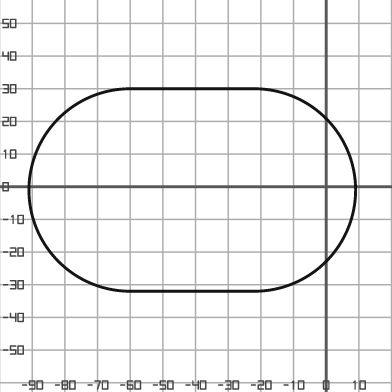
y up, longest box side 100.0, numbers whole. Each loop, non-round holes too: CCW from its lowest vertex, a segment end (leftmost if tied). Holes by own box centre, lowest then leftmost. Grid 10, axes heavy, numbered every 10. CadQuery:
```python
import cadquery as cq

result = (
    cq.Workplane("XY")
    .moveTo(-60.0, -32.0)
    .lineTo(-22.0, -32.0)
    .threePointArc((9.0, -1.0), (-22.0, 30.0))
    .lineTo(-60.0, 30.0)
    .threePointArc((-91.0, -1.0), (-60.0, -32.0))
    .close()
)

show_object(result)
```